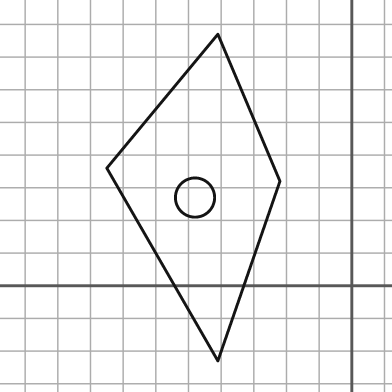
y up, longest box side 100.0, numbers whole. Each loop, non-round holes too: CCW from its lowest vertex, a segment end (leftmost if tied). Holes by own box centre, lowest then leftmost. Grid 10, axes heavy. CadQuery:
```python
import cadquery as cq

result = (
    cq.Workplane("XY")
    .moveTo(-41.0, -23.0)
    .lineTo(-22.0, 32.0)
    .lineTo(-41.0, 77.0)
    .lineTo(-75.0, 36.0)
    .close()
    .moveTo(-48.0, 27.0)
    .circle(6.0)
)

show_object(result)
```